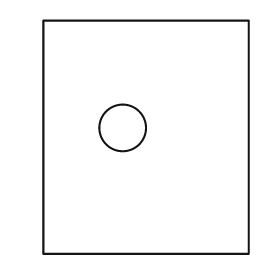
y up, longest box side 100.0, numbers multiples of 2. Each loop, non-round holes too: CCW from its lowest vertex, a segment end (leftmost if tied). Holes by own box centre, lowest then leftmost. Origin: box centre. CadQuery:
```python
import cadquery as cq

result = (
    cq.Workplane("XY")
    .moveTo(-44.0, -50.0)
    .lineTo(44.0, -50.0)
    .lineTo(44.0, 50.0)
    .lineTo(-44.0, 50.0)
    .close()
    .moveTo(-10.0, 4.0)
    .circle(10.0)
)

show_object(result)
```